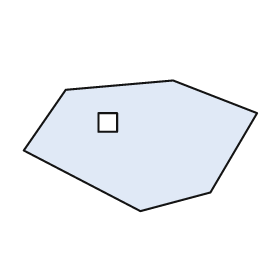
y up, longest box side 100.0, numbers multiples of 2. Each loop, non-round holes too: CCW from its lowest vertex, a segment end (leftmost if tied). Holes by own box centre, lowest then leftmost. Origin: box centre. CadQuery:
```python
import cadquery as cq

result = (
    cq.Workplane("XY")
    .moveTo(0.0, -28.0)
    .lineTo(30.0, -20.0)
    .lineTo(50.0, 14.0)
    .lineTo(14.0, 28.0)
    .lineTo(-32.0, 24.0)
    .lineTo(-50.0, -2.0)
    .close()
    .moveTo(-18.0, 6.0)
    .lineTo(-10.0, 6.0)
    .lineTo(-10.0, 14.0)
    .lineTo(-18.0, 14.0)
    .close()
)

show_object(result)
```